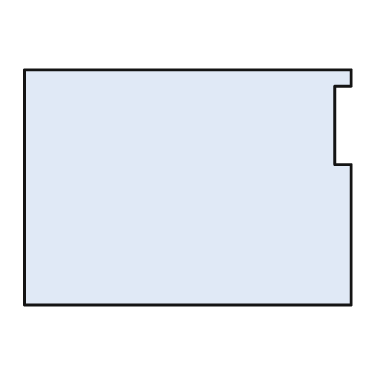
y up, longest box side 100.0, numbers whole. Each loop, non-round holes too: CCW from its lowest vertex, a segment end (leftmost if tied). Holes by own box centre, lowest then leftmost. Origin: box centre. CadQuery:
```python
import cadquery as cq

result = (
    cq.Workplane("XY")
    .moveTo(-50.0, -36.0)
    .lineTo(50.0, -36.0)
    .lineTo(50.0, 7.0)
    .lineTo(45.0, 7.0)
    .lineTo(45.0, 31.0)
    .lineTo(50.0, 31.0)
    .lineTo(50.0, 36.0)
    .lineTo(-50.0, 36.0)
    .close()
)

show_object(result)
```